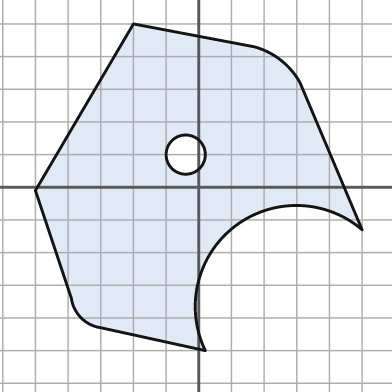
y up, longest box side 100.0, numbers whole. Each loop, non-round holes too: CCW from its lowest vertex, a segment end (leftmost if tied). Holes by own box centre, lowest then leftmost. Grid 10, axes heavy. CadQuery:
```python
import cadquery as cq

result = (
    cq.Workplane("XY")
    .moveTo(2.0, -50.0)
    .threePointArc((11.0, -12.0), (50.0, -13.0))
    .lineTo(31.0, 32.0)
    .threePointArc((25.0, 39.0), (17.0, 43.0))
    .lineTo(-20.0, 50.0)
    .lineTo(-50.0, -1.0)
    .lineTo(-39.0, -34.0)
    .threePointArc((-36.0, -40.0), (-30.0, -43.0))
    .close()
    .moveTo(-4.0, 10.0)
    .circle(6.0)
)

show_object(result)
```